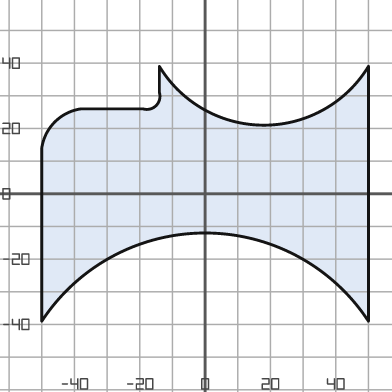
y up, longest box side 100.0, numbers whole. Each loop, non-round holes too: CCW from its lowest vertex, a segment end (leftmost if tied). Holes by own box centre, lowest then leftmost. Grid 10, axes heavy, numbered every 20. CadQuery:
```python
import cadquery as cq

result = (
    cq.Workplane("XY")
    .moveTo(-50.0, -39.0)
    .threePointArc((0.0, -12.0), (50.0, -39.0))
    .lineTo(50.0, 39.0)
    .threePointArc((18.0, 21.0), (-14.0, 39.0))
    .lineTo(-14.0, 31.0)
    .threePointArc((-15.0, 27.0), (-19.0, 26.0))
    .lineTo(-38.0, 26.0)
    .threePointArc((-46.0, 22.0), (-50.0, 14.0))
    .close()
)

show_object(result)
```